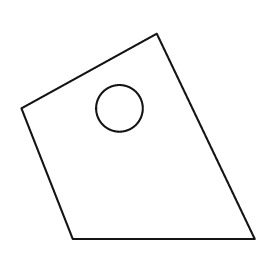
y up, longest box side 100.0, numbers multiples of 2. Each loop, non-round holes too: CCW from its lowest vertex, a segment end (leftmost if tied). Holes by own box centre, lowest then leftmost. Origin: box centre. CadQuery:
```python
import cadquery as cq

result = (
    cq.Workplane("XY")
    .moveTo(-28.0, -44.0)
    .lineTo(50.0, -44.0)
    .lineTo(8.0, 44.0)
    .lineTo(-50.0, 12.0)
    .close()
    .moveTo(-8.0, 12.0)
    .circle(10.0)
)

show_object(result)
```